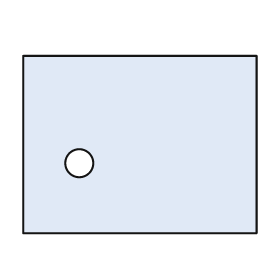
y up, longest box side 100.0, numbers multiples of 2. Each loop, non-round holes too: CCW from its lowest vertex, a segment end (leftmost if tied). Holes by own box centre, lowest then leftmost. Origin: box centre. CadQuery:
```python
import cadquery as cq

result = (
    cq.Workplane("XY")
    .moveTo(-50.0, -38.0)
    .lineTo(50.0, -38.0)
    .lineTo(50.0, 38.0)
    .lineTo(-50.0, 38.0)
    .close()
    .moveTo(-26.0, -8.0)
    .circle(6.0)
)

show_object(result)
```